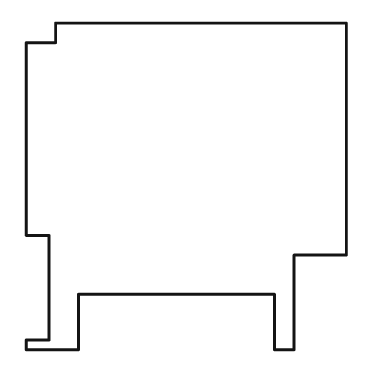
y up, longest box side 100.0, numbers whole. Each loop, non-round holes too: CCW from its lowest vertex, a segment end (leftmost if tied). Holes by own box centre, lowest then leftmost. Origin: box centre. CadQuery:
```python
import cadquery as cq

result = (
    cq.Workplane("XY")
    .moveTo(-49.0, -50.0)
    .lineTo(-33.0, -50.0)
    .lineTo(-33.0, -33.0)
    .lineTo(27.0, -33.0)
    .lineTo(27.0, -50.0)
    .lineTo(33.0, -50.0)
    .lineTo(33.0, -21.0)
    .lineTo(49.0, -21.0)
    .lineTo(49.0, 50.0)
    .lineTo(-40.0, 50.0)
    .lineTo(-40.0, 44.0)
    .lineTo(-49.0, 44.0)
    .lineTo(-49.0, -15.0)
    .lineTo(-42.0, -15.0)
    .lineTo(-42.0, -47.0)
    .lineTo(-49.0, -47.0)
    .close()
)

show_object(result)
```